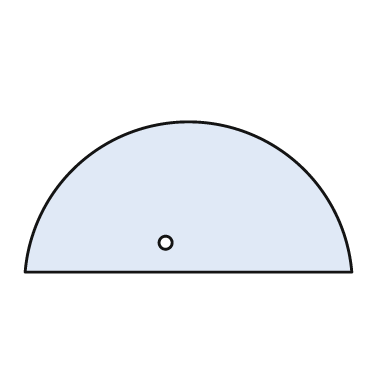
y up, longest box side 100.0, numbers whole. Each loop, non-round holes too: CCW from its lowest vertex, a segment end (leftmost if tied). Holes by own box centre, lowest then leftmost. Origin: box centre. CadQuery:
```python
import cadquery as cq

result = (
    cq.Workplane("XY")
    .moveTo(-50.0, -23.0)
    .lineTo(50.0, -23.0)
    .threePointArc((0.0, 23.0), (-50.0, -23.0))
    .close()
    .moveTo(-7.0, -14.0)
    .circle(2.0)
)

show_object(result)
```